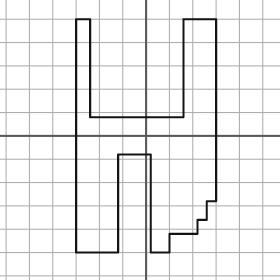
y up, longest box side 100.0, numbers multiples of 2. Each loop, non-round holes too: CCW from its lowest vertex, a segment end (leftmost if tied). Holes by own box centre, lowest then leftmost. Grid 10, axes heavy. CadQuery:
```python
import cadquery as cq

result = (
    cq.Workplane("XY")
    .moveTo(-30.0, -50.0)
    .lineTo(-12.0, -50.0)
    .lineTo(-12.0, -8.0)
    .lineTo(2.0, -8.0)
    .lineTo(2.0, -50.0)
    .lineTo(10.0, -50.0)
    .lineTo(10.0, -42.0)
    .lineTo(22.0, -42.0)
    .lineTo(22.0, -36.0)
    .lineTo(26.0, -36.0)
    .lineTo(26.0, -28.0)
    .lineTo(30.0, -28.0)
    .lineTo(30.0, 50.0)
    .lineTo(16.0, 50.0)
    .lineTo(16.0, 8.0)
    .lineTo(-24.0, 8.0)
    .lineTo(-24.0, 50.0)
    .lineTo(-30.0, 50.0)
    .close()
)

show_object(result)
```